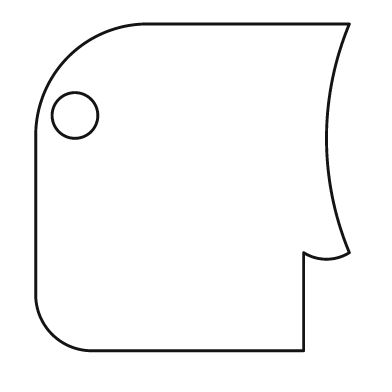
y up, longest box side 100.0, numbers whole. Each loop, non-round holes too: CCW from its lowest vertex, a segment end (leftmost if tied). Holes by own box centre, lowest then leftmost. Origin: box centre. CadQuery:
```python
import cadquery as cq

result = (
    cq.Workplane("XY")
    .moveTo(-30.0, -50.0)
    .lineTo(34.0, -50.0)
    .lineTo(34.0, -20.0)
    .threePointArc((41.0, -22.0), (48.0, -20.0))
    .threePointArc((41.0, 15.0), (48.0, 50.0))
    .lineTo(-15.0, 50.0)
    .threePointArc((-38.0, 40.0), (-48.0, 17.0))
    .lineTo(-48.0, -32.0)
    .threePointArc((-43.0, -45.0), (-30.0, -50.0))
    .close()
    .moveTo(-36.0, 22.0)
    .circle(7.0)
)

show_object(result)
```